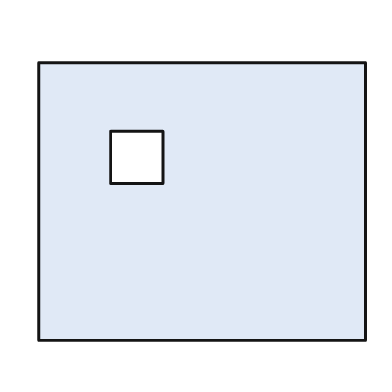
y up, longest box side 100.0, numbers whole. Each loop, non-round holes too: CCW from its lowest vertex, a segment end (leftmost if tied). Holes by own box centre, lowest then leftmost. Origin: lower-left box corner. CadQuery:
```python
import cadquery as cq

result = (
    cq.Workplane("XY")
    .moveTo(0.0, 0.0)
    .lineTo(100.0, 0.0)
    .lineTo(100.0, 85.0)
    .lineTo(0.0, 85.0)
    .close()
    .moveTo(22.0, 48.0)
    .lineTo(38.0, 48.0)
    .lineTo(38.0, 64.0)
    .lineTo(22.0, 64.0)
    .close()
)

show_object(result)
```